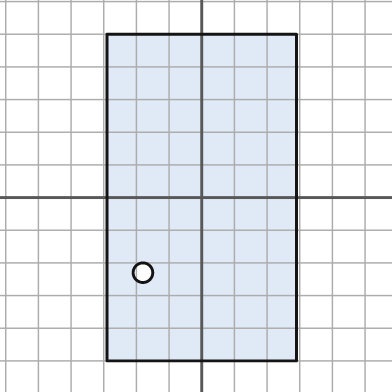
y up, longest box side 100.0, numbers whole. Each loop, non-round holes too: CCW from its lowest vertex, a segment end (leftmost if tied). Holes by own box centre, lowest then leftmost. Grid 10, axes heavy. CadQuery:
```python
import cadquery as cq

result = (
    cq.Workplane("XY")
    .moveTo(-29.0, -50.0)
    .lineTo(29.0, -50.0)
    .lineTo(29.0, 50.0)
    .lineTo(-29.0, 50.0)
    .close()
    .moveTo(-18.0, -23.0)
    .circle(3.0)
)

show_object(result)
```